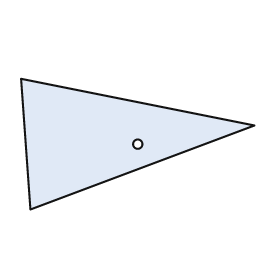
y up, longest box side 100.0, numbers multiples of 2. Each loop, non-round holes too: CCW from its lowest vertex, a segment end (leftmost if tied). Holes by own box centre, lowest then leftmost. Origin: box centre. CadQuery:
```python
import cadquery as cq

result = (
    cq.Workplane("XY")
    .moveTo(-46.0, -28.0)
    .lineTo(50.0, 8.0)
    .lineTo(-50.0, 28.0)
    .close()
    .moveTo(0.0, 0.0)
    .circle(2.0)
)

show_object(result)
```